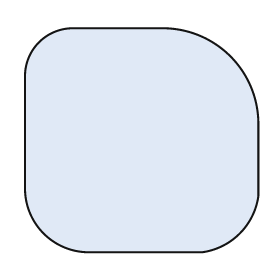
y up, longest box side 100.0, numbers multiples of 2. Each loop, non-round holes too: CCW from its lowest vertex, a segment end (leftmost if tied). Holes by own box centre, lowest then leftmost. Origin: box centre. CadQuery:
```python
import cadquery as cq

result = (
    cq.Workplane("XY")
    .moveTo(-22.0, -48.0)
    .lineTo(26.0, -48.0)
    .threePointArc((42.0, -40.0), (50.0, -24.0))
    .lineTo(50.0, 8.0)
    .threePointArc((38.0, 36.0), (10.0, 48.0))
    .lineTo(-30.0, 48.0)
    .threePointArc((-44.0, 42.0), (-50.0, 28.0))
    .lineTo(-50.0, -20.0)
    .threePointArc((-42.0, -40.0), (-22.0, -48.0))
    .close()
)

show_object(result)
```